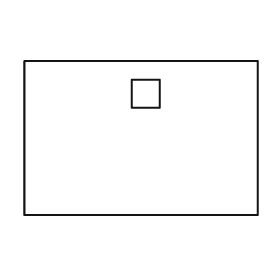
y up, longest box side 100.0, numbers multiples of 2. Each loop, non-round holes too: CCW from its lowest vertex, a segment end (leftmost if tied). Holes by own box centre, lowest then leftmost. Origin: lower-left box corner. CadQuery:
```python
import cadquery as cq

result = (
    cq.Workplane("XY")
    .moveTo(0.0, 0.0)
    .lineTo(100.0, 0.0)
    .lineTo(100.0, 66.0)
    .lineTo(0.0, 66.0)
    .close()
    .moveTo(46.0, 46.0)
    .lineTo(58.0, 46.0)
    .lineTo(58.0, 58.0)
    .lineTo(46.0, 58.0)
    .close()
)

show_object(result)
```